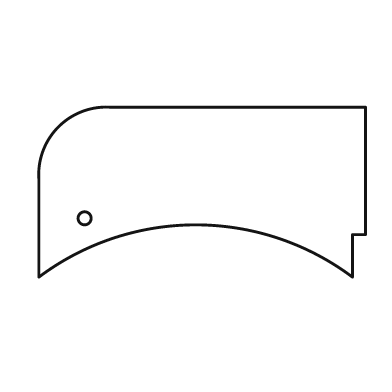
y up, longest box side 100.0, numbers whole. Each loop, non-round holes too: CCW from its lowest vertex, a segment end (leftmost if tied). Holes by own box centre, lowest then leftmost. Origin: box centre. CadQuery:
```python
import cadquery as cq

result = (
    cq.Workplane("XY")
    .moveTo(-50.0, -26.0)
    .threePointArc((-2.0, -10.0), (46.0, -26.0))
    .lineTo(46.0, -13.0)
    .lineTo(50.0, -13.0)
    .lineTo(50.0, 26.0)
    .lineTo(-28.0, 26.0)
    .threePointArc((-44.0, 20.0), (-50.0, 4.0))
    .close()
    .moveTo(-36.0, -8.0)
    .circle(2.0)
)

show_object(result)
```